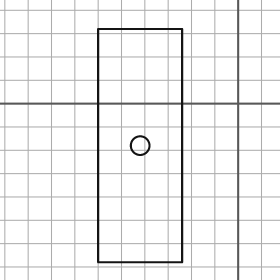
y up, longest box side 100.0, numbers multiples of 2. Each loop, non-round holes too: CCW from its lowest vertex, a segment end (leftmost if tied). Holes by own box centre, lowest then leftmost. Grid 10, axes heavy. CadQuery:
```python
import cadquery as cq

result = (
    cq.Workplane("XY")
    .moveTo(-60.0, -68.0)
    .lineTo(-24.0, -68.0)
    .lineTo(-24.0, 32.0)
    .lineTo(-60.0, 32.0)
    .close()
    .moveTo(-42.0, -18.0)
    .circle(4.0)
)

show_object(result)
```